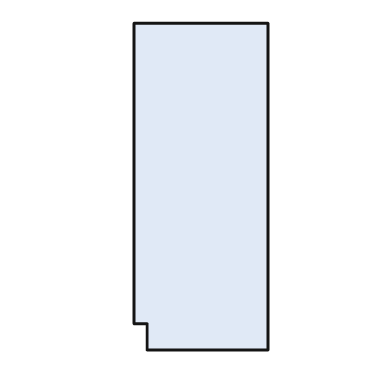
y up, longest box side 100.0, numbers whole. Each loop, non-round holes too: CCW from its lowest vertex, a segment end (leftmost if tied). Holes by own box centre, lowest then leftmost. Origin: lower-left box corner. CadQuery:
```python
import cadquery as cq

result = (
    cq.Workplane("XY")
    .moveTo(4.0, 0.0)
    .lineTo(41.0, 0.0)
    .lineTo(41.0, 100.0)
    .lineTo(0.0, 100.0)
    .lineTo(0.0, 8.0)
    .lineTo(4.0, 8.0)
    .close()
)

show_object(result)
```